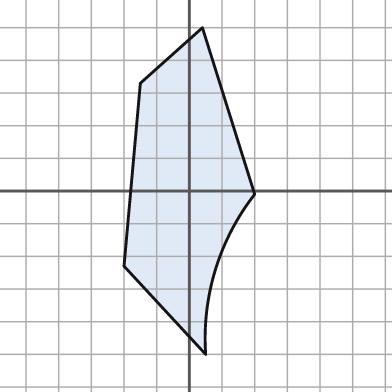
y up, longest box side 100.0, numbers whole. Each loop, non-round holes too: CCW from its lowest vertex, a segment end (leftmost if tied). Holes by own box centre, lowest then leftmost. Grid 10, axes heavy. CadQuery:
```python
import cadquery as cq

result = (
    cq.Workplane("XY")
    .moveTo(5.0, -50.0)
    .threePointArc((8.0, -24.0), (20.0, -1.0))
    .lineTo(4.0, 50.0)
    .lineTo(-15.0, 33.0)
    .lineTo(-20.0, -23.0)
    .close()
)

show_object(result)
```